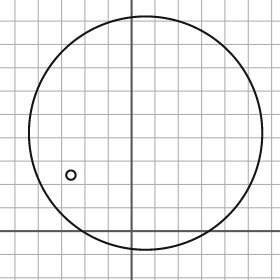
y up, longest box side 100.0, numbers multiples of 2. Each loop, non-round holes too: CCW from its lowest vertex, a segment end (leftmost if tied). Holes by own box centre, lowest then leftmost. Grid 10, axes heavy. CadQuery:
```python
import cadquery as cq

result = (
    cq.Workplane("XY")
    .moveTo(6.0, 42.0)
    .circle(50.0)
    .moveTo(-26.0, 24.0)
    .circle(2.0)
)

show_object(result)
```